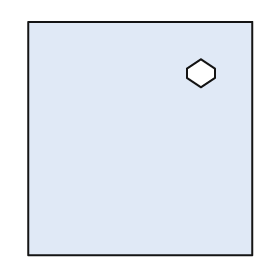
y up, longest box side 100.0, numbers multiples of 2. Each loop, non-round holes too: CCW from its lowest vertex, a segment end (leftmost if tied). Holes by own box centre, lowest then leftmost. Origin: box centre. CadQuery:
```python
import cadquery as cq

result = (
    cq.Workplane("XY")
    .moveTo(-48.0, -50.0)
    .lineTo(48.0, -50.0)
    .lineTo(48.0, 50.0)
    .lineTo(-48.0, 50.0)
    .close()
    .moveTo(26.0, 22.0)
    .lineTo(32.0, 26.0)
    .lineTo(32.0, 30.0)
    .lineTo(26.0, 34.0)
    .lineTo(20.0, 30.0)
    .lineTo(20.0, 26.0)
    .close()
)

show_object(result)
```